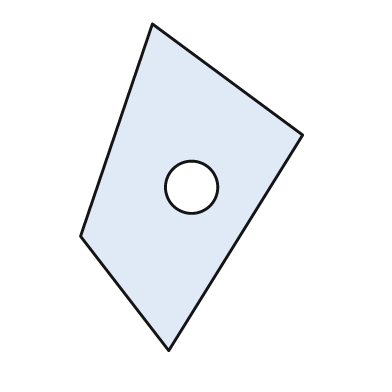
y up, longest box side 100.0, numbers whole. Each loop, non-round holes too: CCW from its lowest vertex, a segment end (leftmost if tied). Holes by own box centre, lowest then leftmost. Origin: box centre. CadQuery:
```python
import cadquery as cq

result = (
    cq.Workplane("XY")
    .moveTo(-7.0, -50.0)
    .lineTo(34.0, 16.0)
    .lineTo(-12.0, 50.0)
    .lineTo(-34.0, -15.0)
    .close()
    .moveTo(0.0, 0.0)
    .circle(8.0)
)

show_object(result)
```